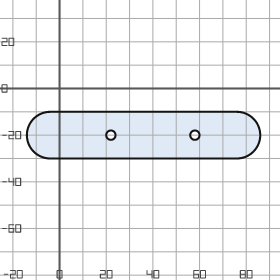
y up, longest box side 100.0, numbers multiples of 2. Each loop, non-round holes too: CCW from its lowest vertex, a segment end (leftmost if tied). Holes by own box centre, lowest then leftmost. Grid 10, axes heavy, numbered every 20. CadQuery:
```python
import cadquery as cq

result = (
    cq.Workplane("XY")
    .moveTo(-4.0, -30.0)
    .lineTo(76.0, -30.0)
    .threePointArc((86.0, -20.0), (76.0, -10.0))
    .lineTo(-4.0, -10.0)
    .threePointArc((-14.0, -20.0), (-4.0, -30.0))
    .close()
    .moveTo(22.0, -20.0)
    .circle(2.0)
    .moveTo(58.0, -20.0)
    .circle(2.0)
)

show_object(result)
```